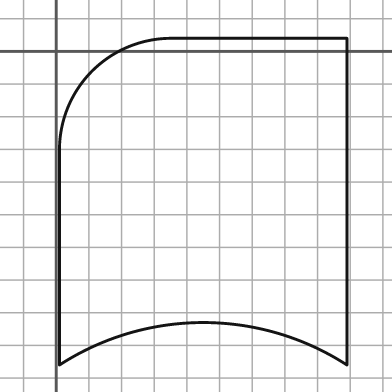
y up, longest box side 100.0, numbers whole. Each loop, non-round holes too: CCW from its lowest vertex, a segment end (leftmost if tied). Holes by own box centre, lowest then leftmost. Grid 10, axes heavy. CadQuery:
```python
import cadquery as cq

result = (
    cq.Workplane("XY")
    .moveTo(1.0, -96.0)
    .threePointArc((45.0, -83.0), (89.0, -96.0))
    .lineTo(89.0, 4.0)
    .lineTo(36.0, 4.0)
    .threePointArc((11.0, -6.0), (1.0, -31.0))
    .close()
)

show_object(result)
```